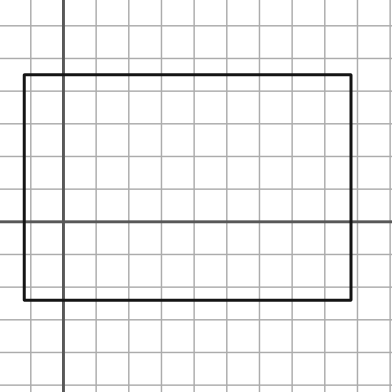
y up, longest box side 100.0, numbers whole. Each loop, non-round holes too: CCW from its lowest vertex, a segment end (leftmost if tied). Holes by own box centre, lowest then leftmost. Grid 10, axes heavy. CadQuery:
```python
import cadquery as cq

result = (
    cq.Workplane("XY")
    .moveTo(-12.0, -24.0)
    .lineTo(88.0, -24.0)
    .lineTo(88.0, 45.0)
    .lineTo(-12.0, 45.0)
    .close()
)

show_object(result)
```